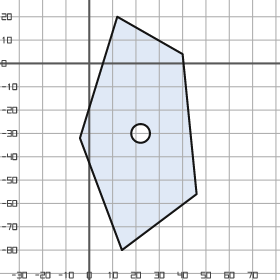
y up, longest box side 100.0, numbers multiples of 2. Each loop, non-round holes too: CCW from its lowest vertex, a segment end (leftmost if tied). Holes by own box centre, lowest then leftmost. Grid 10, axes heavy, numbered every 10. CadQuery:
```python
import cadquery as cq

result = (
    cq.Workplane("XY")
    .moveTo(14.0, -80.0)
    .lineTo(46.0, -56.0)
    .lineTo(40.0, 4.0)
    .lineTo(12.0, 20.0)
    .lineTo(-4.0, -32.0)
    .close()
    .moveTo(22.0, -30.0)
    .circle(4.0)
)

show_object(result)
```